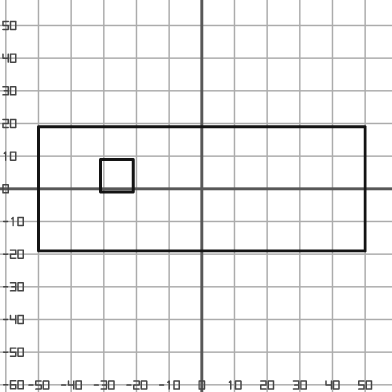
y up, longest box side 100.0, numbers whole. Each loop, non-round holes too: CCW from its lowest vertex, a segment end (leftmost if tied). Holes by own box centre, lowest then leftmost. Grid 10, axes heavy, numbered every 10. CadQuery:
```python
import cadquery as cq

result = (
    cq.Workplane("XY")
    .moveTo(-50.0, -19.0)
    .lineTo(50.0, -19.0)
    .lineTo(50.0, 19.0)
    .lineTo(-50.0, 19.0)
    .close()
    .moveTo(-31.0, -1.0)
    .lineTo(-21.0, -1.0)
    .lineTo(-21.0, 9.0)
    .lineTo(-31.0, 9.0)
    .close()
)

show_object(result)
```